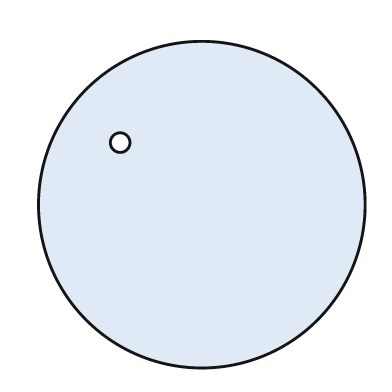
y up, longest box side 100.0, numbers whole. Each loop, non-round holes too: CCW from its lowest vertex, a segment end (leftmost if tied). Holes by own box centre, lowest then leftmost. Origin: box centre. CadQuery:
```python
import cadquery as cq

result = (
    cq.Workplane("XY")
    .moveTo(0.0, 0.0)
    .circle(50.0)
    .moveTo(-25.0, 19.0)
    .circle(3.0)
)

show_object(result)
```